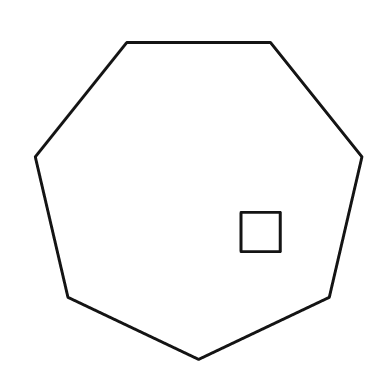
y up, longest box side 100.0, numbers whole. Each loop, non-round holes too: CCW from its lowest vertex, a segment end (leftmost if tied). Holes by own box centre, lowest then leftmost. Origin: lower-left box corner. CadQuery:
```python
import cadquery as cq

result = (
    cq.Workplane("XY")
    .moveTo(50.0, 0.0)
    .lineTo(90.0, 19.0)
    .lineTo(100.0, 62.0)
    .lineTo(72.0, 97.0)
    .lineTo(28.0, 97.0)
    .lineTo(0.0, 62.0)
    .lineTo(10.0, 19.0)
    .close()
    .moveTo(63.0, 33.0)
    .lineTo(75.0, 33.0)
    .lineTo(75.0, 45.0)
    .lineTo(63.0, 45.0)
    .close()
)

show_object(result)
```